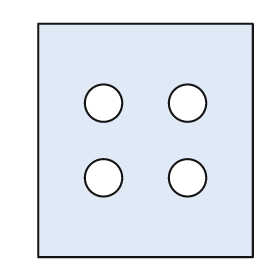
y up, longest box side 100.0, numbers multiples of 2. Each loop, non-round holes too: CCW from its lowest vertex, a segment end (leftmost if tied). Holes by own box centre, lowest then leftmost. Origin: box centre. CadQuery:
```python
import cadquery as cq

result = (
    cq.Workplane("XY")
    .moveTo(-46.0, -50.0)
    .lineTo(46.0, -50.0)
    .lineTo(46.0, 50.0)
    .lineTo(-46.0, 50.0)
    .close()
    .moveTo(-18.0, -16.0)
    .circle(8.0)
    .moveTo(18.0, -16.0)
    .circle(8.0)
    .moveTo(-18.0, 16.0)
    .circle(8.0)
    .moveTo(18.0, 16.0)
    .circle(8.0)
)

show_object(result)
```